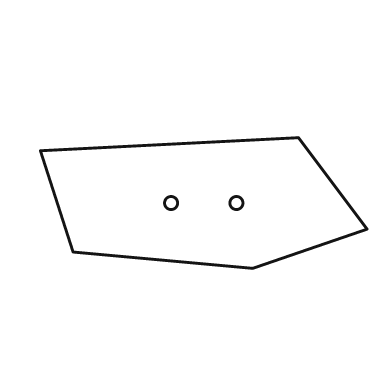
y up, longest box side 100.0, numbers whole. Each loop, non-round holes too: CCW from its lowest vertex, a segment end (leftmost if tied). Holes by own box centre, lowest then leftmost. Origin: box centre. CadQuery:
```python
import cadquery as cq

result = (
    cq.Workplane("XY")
    .moveTo(15.0, -20.0)
    .lineTo(50.0, -8.0)
    .lineTo(29.0, 20.0)
    .lineTo(-50.0, 16.0)
    .lineTo(-40.0, -15.0)
    .close()
    .moveTo(-10.0, 0.0)
    .circle(2.0)
    .moveTo(10.0, 0.0)
    .circle(2.0)
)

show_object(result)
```